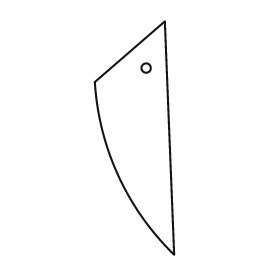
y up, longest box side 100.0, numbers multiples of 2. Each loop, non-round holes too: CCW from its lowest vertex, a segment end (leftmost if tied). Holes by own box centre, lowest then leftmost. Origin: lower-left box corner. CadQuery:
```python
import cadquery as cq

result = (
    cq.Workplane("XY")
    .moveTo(34.0, 0.0)
    .lineTo(30.0, 100.0)
    .lineTo(0.0, 74.0)
    .threePointArc((10.0, 34.0), (34.0, 0.0))
    .close()
    .moveTo(22.0, 80.0)
    .circle(2.0)
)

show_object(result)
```